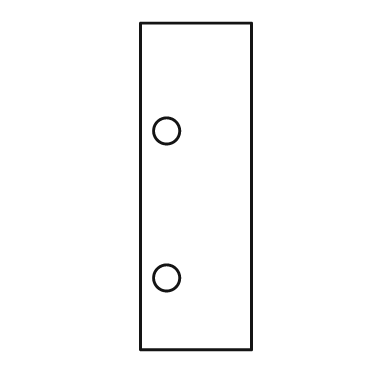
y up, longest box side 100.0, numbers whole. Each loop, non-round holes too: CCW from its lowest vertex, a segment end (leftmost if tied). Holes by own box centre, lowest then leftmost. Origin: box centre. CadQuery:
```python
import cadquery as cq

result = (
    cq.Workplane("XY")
    .moveTo(-17.0, -50.0)
    .lineTo(17.0, -50.0)
    .lineTo(17.0, 50.0)
    .lineTo(-17.0, 50.0)
    .close()
    .moveTo(-9.0, -28.0)
    .circle(4.0)
    .moveTo(-9.0, 17.0)
    .circle(4.0)
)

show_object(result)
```